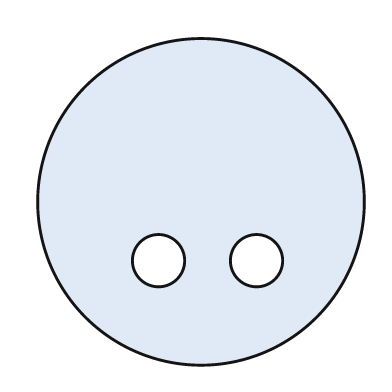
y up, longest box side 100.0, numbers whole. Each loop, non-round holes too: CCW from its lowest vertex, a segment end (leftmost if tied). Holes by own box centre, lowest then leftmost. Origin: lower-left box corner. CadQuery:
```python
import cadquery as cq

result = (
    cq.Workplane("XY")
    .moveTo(50.0, 50.0)
    .circle(50.0)
    .moveTo(37.0, 32.0)
    .circle(8.0)
    .moveTo(67.0, 32.0)
    .circle(8.0)
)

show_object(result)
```